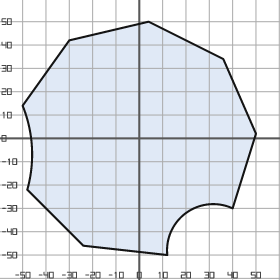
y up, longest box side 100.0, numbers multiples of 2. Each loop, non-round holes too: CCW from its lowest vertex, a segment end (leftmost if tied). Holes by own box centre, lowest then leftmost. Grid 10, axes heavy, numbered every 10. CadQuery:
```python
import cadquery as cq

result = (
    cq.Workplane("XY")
    .moveTo(12.0, -50.0)
    .threePointArc((20.0, -32.0), (40.0, -30.0))
    .lineTo(50.0, 2.0)
    .lineTo(36.0, 34.0)
    .lineTo(4.0, 50.0)
    .lineTo(-30.0, 42.0)
    .lineTo(-50.0, 14.0)
    .threePointArc((-46.0, -4.0), (-48.0, -22.0))
    .lineTo(-24.0, -46.0)
    .close()
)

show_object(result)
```